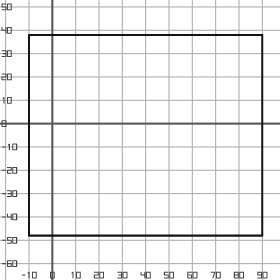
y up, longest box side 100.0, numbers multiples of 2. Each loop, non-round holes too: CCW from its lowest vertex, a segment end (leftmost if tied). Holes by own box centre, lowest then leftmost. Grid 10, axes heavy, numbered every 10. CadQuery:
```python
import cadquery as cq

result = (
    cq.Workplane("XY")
    .moveTo(-10.0, -48.0)
    .lineTo(90.0, -48.0)
    .lineTo(90.0, 38.0)
    .lineTo(-10.0, 38.0)
    .close()
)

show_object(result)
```